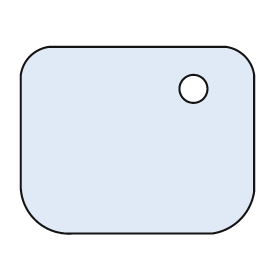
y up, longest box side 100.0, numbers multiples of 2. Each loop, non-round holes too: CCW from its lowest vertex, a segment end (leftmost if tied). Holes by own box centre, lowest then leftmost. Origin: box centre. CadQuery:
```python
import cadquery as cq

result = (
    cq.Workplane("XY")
    .moveTo(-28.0, -40.0)
    .lineTo(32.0, -40.0)
    .threePointArc((44.0, -34.0), (50.0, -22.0))
    .lineTo(50.0, 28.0)
    .threePointArc((46.0, 36.0), (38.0, 40.0))
    .lineTo(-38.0, 40.0)
    .threePointArc((-46.0, 36.0), (-50.0, 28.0))
    .lineTo(-50.0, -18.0)
    .threePointArc((-44.0, -34.0), (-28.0, -40.0))
    .close()
    .moveTo(24.0, 22.0)
    .circle(6.0)
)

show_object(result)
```